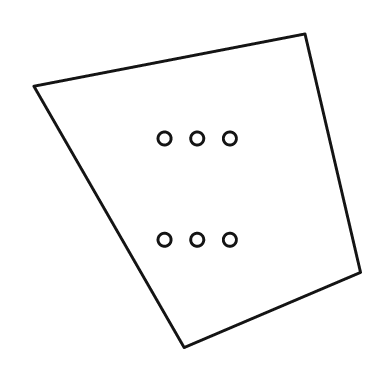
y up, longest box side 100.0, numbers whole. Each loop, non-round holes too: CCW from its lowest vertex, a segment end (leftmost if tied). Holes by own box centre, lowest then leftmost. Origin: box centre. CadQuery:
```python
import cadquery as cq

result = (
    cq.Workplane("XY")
    .moveTo(-4.0, -48.0)
    .lineTo(50.0, -25.0)
    .lineTo(33.0, 48.0)
    .lineTo(-50.0, 32.0)
    .close()
    .moveTo(-10.0, -15.0)
    .circle(2.0)
    .moveTo(0.0, -15.0)
    .circle(2.0)
    .moveTo(10.0, -15.0)
    .circle(2.0)
    .moveTo(-10.0, 16.0)
    .circle(2.0)
    .moveTo(0.0, 16.0)
    .circle(2.0)
    .moveTo(10.0, 16.0)
    .circle(2.0)
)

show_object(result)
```